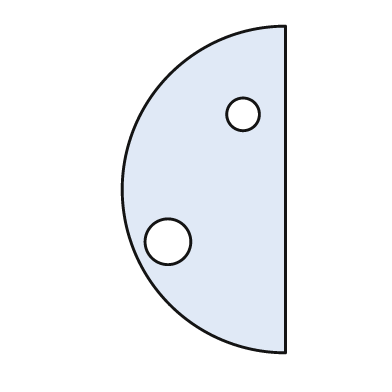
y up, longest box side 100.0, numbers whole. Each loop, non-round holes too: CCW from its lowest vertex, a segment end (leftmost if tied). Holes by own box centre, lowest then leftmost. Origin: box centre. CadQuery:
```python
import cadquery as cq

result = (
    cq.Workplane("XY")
    .moveTo(25.0, -50.0)
    .lineTo(25.0, 50.0)
    .threePointArc((-25.0, 0.0), (25.0, -50.0))
    .close()
    .moveTo(-11.0, -16.0)
    .circle(7.0)
    .moveTo(12.0, 23.0)
    .circle(5.0)
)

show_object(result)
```